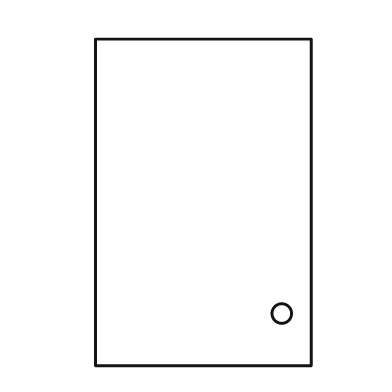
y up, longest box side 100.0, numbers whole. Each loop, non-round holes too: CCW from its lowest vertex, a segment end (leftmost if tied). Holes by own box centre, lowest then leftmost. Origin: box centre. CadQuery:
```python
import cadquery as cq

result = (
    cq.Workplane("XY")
    .moveTo(-33.0, -50.0)
    .lineTo(33.0, -50.0)
    .lineTo(33.0, 50.0)
    .lineTo(-33.0, 50.0)
    .close()
    .moveTo(24.0, -34.0)
    .circle(3.0)
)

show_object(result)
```